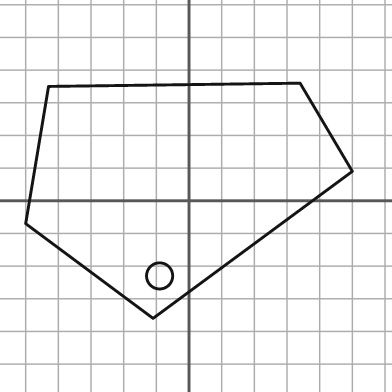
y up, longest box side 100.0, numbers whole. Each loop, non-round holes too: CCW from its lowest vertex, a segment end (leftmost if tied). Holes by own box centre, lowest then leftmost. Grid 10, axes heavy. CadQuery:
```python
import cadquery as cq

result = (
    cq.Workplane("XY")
    .moveTo(-11.0, -36.0)
    .lineTo(50.0, 9.0)
    .lineTo(34.0, 36.0)
    .lineTo(-43.0, 35.0)
    .lineTo(-50.0, -7.0)
    .close()
    .moveTo(-9.0, -23.0)
    .circle(4.0)
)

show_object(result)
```